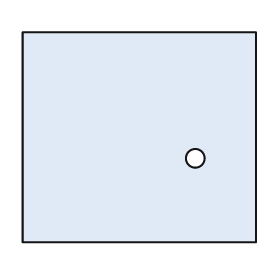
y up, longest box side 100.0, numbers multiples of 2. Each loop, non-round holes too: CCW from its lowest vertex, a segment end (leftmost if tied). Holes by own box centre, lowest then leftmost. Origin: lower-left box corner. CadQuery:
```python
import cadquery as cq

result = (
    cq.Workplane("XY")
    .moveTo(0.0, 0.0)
    .lineTo(100.0, 0.0)
    .lineTo(100.0, 90.0)
    .lineTo(0.0, 90.0)
    .close()
    .moveTo(74.0, 36.0)
    .circle(4.0)
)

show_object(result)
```